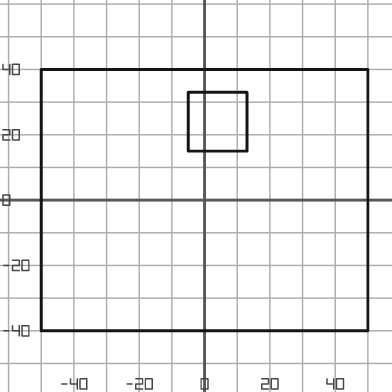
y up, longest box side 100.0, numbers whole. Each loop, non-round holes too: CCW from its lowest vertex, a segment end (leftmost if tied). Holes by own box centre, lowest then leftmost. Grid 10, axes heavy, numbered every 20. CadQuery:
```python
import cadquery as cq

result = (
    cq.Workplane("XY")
    .moveTo(-50.0, -40.0)
    .lineTo(50.0, -40.0)
    .lineTo(50.0, 40.0)
    .lineTo(-50.0, 40.0)
    .close()
    .moveTo(-5.0, 15.0)
    .lineTo(13.0, 15.0)
    .lineTo(13.0, 33.0)
    .lineTo(-5.0, 33.0)
    .close()
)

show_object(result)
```